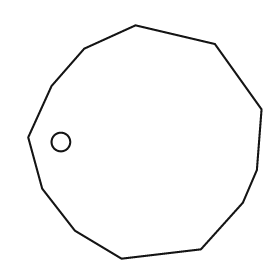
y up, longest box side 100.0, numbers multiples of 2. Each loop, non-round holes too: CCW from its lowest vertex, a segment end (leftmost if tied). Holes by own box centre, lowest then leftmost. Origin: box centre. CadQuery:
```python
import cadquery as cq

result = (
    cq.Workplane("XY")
    .moveTo(-10.0, -50.0)
    .lineTo(24.0, -46.0)
    .lineTo(42.0, -26.0)
    .lineTo(48.0, -12.0)
    .lineTo(50.0, 14.0)
    .lineTo(30.0, 42.0)
    .lineTo(-4.0, 50.0)
    .lineTo(-26.0, 40.0)
    .lineTo(-40.0, 24.0)
    .lineTo(-50.0, 2.0)
    .lineTo(-44.0, -20.0)
    .lineTo(-30.0, -38.0)
    .close()
    .moveTo(-36.0, 0.0)
    .circle(4.0)
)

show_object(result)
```